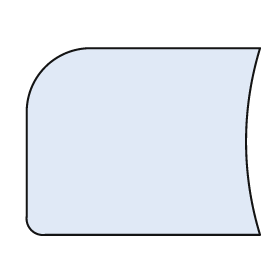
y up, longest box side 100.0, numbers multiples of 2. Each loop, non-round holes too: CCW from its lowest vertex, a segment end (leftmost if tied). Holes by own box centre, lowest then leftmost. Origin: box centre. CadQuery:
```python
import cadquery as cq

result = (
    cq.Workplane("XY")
    .moveTo(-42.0, -40.0)
    .lineTo(50.0, -40.0)
    .threePointArc((44.0, 0.0), (50.0, 40.0))
    .lineTo(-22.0, 40.0)
    .threePointArc((-42.0, 32.0), (-50.0, 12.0))
    .lineTo(-50.0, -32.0)
    .threePointArc((-48.0, -38.0), (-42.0, -40.0))
    .close()
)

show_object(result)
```